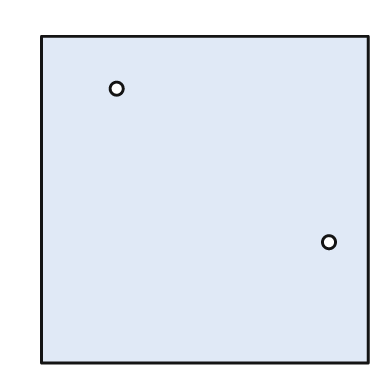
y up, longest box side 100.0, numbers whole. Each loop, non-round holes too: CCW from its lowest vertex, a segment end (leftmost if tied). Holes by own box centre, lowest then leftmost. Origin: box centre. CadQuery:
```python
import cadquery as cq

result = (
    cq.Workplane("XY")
    .moveTo(-50.0, -50.0)
    .lineTo(50.0, -50.0)
    .lineTo(50.0, 50.0)
    .lineTo(-50.0, 50.0)
    .close()
    .moveTo(38.0, -13.0)
    .circle(2.0)
    .moveTo(-27.0, 34.0)
    .circle(2.0)
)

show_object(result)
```